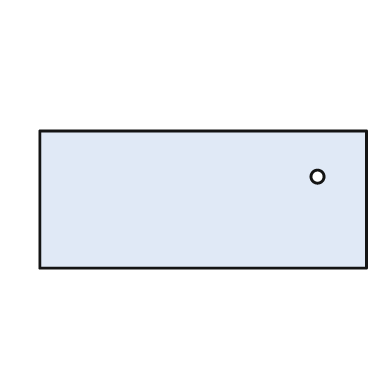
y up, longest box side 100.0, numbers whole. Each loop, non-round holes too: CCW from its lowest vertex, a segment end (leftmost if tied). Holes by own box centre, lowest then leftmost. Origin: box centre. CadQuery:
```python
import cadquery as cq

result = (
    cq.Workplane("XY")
    .moveTo(-50.0, -21.0)
    .lineTo(50.0, -21.0)
    .lineTo(50.0, 21.0)
    .lineTo(-50.0, 21.0)
    .close()
    .moveTo(35.0, 7.0)
    .circle(2.0)
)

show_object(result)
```